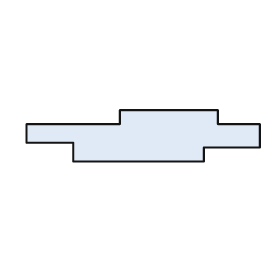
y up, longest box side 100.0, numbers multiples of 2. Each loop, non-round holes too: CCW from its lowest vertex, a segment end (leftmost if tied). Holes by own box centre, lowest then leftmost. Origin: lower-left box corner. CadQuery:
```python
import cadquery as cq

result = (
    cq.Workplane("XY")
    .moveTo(20.0, 0.0)
    .lineTo(76.0, 0.0)
    .lineTo(76.0, 6.0)
    .lineTo(100.0, 6.0)
    .lineTo(100.0, 16.0)
    .lineTo(82.0, 16.0)
    .lineTo(82.0, 22.0)
    .lineTo(40.0, 22.0)
    .lineTo(40.0, 16.0)
    .lineTo(0.0, 16.0)
    .lineTo(0.0, 8.0)
    .lineTo(20.0, 8.0)
    .close()
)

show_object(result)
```